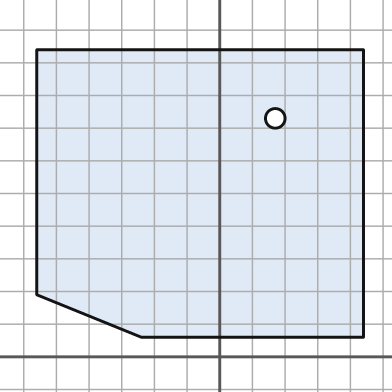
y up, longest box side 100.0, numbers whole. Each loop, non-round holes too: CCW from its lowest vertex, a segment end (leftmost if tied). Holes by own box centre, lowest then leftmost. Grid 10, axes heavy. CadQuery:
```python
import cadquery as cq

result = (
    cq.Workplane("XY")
    .moveTo(-24.0, 6.0)
    .lineTo(44.0, 6.0)
    .lineTo(44.0, 94.0)
    .lineTo(-56.0, 94.0)
    .lineTo(-56.0, 19.0)
    .close()
    .moveTo(17.0, 73.0)
    .circle(3.0)
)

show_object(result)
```